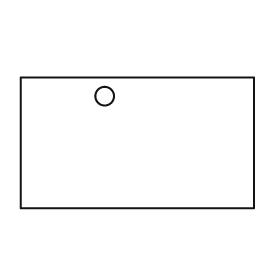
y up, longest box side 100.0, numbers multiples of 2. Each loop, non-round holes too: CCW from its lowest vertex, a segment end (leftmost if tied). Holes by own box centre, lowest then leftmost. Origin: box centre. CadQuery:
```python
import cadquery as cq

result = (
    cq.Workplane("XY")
    .moveTo(-50.0, -28.0)
    .lineTo(50.0, -28.0)
    .lineTo(50.0, 28.0)
    .lineTo(-50.0, 28.0)
    .close()
    .moveTo(-14.0, 20.0)
    .circle(4.0)
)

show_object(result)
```